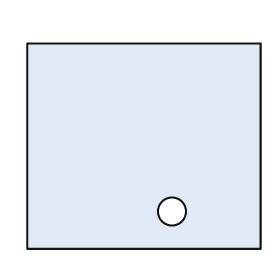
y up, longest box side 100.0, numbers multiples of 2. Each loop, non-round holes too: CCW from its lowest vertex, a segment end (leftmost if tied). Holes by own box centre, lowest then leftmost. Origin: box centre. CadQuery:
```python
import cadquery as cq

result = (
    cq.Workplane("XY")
    .moveTo(-50.0, -44.0)
    .lineTo(50.0, -44.0)
    .lineTo(50.0, 44.0)
    .lineTo(-50.0, 44.0)
    .close()
    .moveTo(12.0, -28.0)
    .circle(6.0)
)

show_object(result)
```